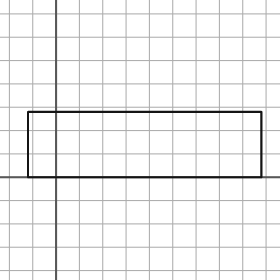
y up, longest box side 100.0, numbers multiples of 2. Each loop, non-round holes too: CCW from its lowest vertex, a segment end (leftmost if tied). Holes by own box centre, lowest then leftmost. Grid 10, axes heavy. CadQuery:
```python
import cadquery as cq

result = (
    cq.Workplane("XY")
    .moveTo(-12.0, 0.0)
    .lineTo(88.0, 0.0)
    .lineTo(88.0, 28.0)
    .lineTo(-12.0, 28.0)
    .close()
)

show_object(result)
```